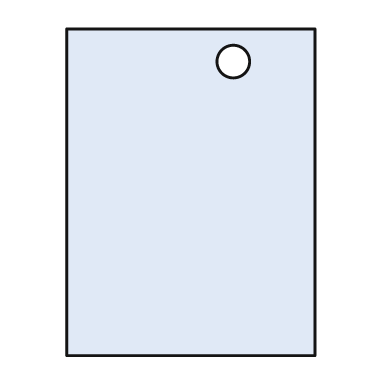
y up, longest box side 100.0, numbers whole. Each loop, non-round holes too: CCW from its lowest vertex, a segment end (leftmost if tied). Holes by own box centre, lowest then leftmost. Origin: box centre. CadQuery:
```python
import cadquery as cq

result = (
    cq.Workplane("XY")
    .moveTo(-38.0, -50.0)
    .lineTo(38.0, -50.0)
    .lineTo(38.0, 50.0)
    .lineTo(-38.0, 50.0)
    .close()
    .moveTo(13.0, 40.0)
    .circle(5.0)
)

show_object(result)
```